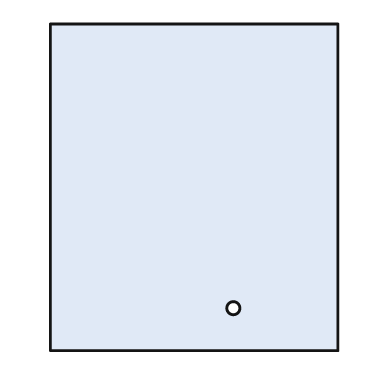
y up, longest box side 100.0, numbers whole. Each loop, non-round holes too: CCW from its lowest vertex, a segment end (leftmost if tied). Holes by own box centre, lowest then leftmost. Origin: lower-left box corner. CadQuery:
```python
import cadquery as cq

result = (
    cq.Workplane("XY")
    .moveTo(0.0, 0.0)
    .lineTo(88.0, 0.0)
    .lineTo(88.0, 100.0)
    .lineTo(0.0, 100.0)
    .close()
    .moveTo(56.0, 13.0)
    .circle(2.0)
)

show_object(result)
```